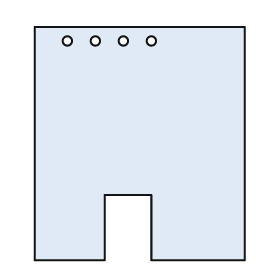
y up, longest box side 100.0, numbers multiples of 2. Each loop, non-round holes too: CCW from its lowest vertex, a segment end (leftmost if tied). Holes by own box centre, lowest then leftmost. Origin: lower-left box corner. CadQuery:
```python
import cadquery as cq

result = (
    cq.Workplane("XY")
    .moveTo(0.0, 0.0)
    .lineTo(30.0, 0.0)
    .lineTo(30.0, 28.0)
    .lineTo(50.0, 28.0)
    .lineTo(50.0, 0.0)
    .lineTo(90.0, 0.0)
    .lineTo(90.0, 100.0)
    .lineTo(0.0, 100.0)
    .close()
    .moveTo(14.0, 94.0)
    .circle(2.0)
    .moveTo(26.0, 94.0)
    .circle(2.0)
    .moveTo(38.0, 94.0)
    .circle(2.0)
    .moveTo(50.0, 94.0)
    .circle(2.0)
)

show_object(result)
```